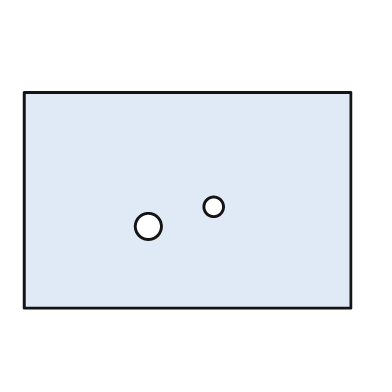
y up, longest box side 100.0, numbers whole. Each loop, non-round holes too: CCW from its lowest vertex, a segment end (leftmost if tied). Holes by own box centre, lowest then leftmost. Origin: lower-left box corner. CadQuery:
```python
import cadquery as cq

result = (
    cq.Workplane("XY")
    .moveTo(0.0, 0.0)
    .lineTo(100.0, 0.0)
    .lineTo(100.0, 66.0)
    .lineTo(0.0, 66.0)
    .close()
    .moveTo(38.0, 25.0)
    .circle(4.0)
    .moveTo(58.0, 31.0)
    .circle(3.0)
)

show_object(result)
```